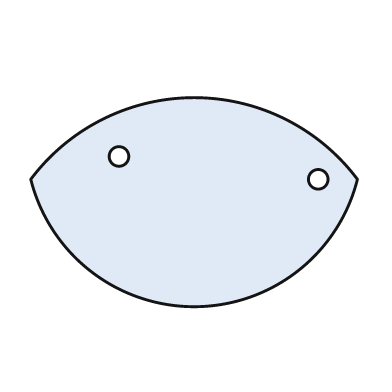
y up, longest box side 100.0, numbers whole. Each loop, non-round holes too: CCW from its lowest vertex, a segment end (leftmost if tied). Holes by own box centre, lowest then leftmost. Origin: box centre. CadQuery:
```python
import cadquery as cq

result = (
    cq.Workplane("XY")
    .moveTo(-50.0, 7.0)
    .threePointArc((0.0, -32.0), (50.0, 7.0))
    .threePointArc((0.0, 32.0), (-50.0, 7.0))
    .close()
    .moveTo(38.0, 7.0)
    .circle(3.0)
    .moveTo(-23.0, 14.0)
    .circle(3.0)
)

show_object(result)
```